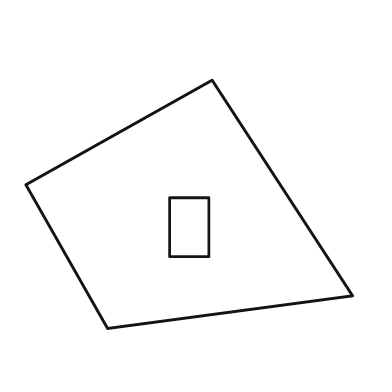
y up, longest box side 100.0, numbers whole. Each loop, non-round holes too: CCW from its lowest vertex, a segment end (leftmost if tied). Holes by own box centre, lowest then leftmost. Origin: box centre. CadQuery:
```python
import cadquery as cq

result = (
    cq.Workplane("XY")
    .moveTo(-25.0, -38.0)
    .lineTo(50.0, -28.0)
    .lineTo(7.0, 38.0)
    .lineTo(-50.0, 6.0)
    .close()
    .moveTo(-6.0, -16.0)
    .lineTo(6.0, -16.0)
    .lineTo(6.0, 2.0)
    .lineTo(-6.0, 2.0)
    .close()
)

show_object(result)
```